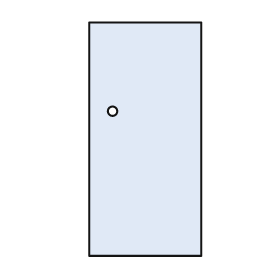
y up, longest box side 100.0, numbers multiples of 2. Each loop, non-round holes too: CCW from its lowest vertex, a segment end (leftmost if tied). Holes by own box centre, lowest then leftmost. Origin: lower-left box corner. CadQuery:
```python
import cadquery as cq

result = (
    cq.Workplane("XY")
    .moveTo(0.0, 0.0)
    .lineTo(48.0, 0.0)
    .lineTo(48.0, 100.0)
    .lineTo(0.0, 100.0)
    .close()
    .moveTo(10.0, 62.0)
    .circle(2.0)
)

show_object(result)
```